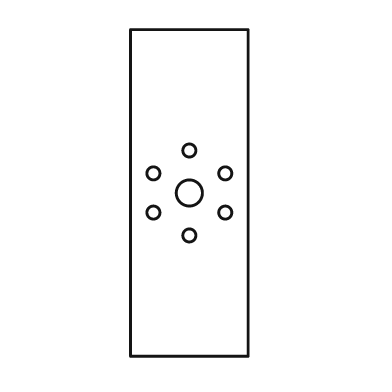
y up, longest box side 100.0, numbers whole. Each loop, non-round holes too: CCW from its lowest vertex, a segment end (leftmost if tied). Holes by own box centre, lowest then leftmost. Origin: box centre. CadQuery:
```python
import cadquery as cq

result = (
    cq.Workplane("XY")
    .moveTo(-18.0, -50.0)
    .lineTo(18.0, -50.0)
    .lineTo(18.0, 50.0)
    .lineTo(-18.0, 50.0)
    .close()
    .moveTo(0.0, -13.0)
    .circle(2.0)
    .moveTo(-11.0, -6.0)
    .circle(2.0)
    .moveTo(11.0, -6.0)
    .circle(2.0)
    .moveTo(0.0, 0.0)
    .circle(4.0)
    .moveTo(-11.0, 6.0)
    .circle(2.0)
    .moveTo(11.0, 6.0)
    .circle(2.0)
    .moveTo(0.0, 13.0)
    .circle(2.0)
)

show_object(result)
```